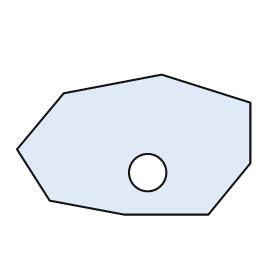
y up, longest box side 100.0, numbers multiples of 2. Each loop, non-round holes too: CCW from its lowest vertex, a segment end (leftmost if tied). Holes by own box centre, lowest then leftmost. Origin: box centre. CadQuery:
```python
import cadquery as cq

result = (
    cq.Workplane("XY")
    .moveTo(-4.0, -30.0)
    .lineTo(32.0, -30.0)
    .lineTo(50.0, -8.0)
    .lineTo(50.0, 18.0)
    .lineTo(12.0, 30.0)
    .lineTo(-30.0, 22.0)
    .lineTo(-50.0, -2.0)
    .lineTo(-36.0, -24.0)
    .close()
    .moveTo(6.0, -12.0)
    .circle(8.0)
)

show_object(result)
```